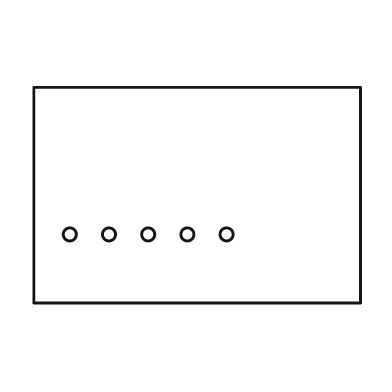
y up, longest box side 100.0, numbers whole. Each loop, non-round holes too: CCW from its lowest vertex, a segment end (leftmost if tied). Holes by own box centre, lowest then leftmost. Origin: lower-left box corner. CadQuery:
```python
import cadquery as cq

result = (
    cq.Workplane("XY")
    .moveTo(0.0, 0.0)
    .lineTo(100.0, 0.0)
    .lineTo(100.0, 66.0)
    .lineTo(0.0, 66.0)
    .close()
    .moveTo(11.0, 21.0)
    .circle(2.0)
    .moveTo(23.0, 21.0)
    .circle(2.0)
    .moveTo(35.0, 21.0)
    .circle(2.0)
    .moveTo(47.0, 21.0)
    .circle(2.0)
    .moveTo(59.0, 21.0)
    .circle(2.0)
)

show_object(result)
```